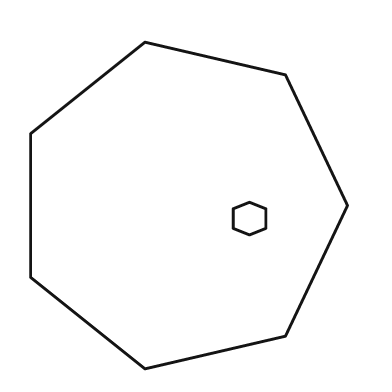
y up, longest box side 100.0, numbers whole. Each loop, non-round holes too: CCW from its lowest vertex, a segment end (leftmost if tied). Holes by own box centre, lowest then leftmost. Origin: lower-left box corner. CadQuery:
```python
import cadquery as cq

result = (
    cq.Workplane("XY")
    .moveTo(35.0, 0.0)
    .lineTo(78.0, 10.0)
    .lineTo(97.0, 50.0)
    .lineTo(78.0, 90.0)
    .lineTo(35.0, 100.0)
    .lineTo(0.0, 72.0)
    .lineTo(0.0, 28.0)
    .close()
    .moveTo(67.0, 41.0)
    .lineTo(72.0, 43.0)
    .lineTo(72.0, 49.0)
    .lineTo(67.0, 51.0)
    .lineTo(62.0, 49.0)
    .lineTo(62.0, 43.0)
    .close()
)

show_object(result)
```